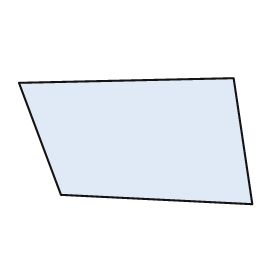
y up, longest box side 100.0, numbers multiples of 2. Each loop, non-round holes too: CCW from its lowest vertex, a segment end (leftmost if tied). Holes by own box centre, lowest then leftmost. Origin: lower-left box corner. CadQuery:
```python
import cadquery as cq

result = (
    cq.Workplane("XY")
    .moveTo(100.0, 0.0)
    .lineTo(92.0, 54.0)
    .lineTo(0.0, 52.0)
    .lineTo(18.0, 4.0)
    .close()
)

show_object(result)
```